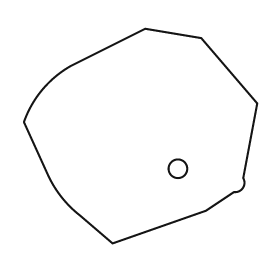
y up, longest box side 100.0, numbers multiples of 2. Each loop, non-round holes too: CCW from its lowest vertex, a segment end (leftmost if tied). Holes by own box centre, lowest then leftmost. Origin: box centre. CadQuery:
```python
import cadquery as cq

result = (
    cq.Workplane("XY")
    .moveTo(-12.0, -46.0)
    .lineTo(28.0, -32.0)
    .lineTo(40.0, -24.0)
    .threePointArc((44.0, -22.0), (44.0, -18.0))
    .lineTo(50.0, 14.0)
    .lineTo(26.0, 42.0)
    .lineTo(2.0, 46.0)
    .lineTo(-30.0, 30.0)
    .threePointArc((-42.0, 20.0), (-50.0, 6.0))
    .lineTo(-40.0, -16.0)
    .threePointArc((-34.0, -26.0), (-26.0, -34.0))
    .close()
    .moveTo(16.0, -14.0)
    .circle(4.0)
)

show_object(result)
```